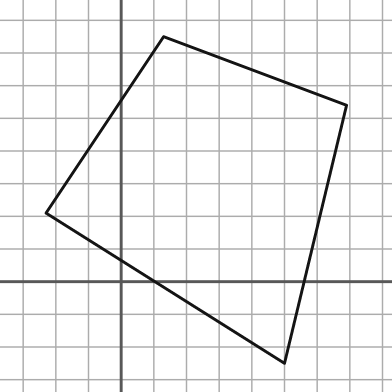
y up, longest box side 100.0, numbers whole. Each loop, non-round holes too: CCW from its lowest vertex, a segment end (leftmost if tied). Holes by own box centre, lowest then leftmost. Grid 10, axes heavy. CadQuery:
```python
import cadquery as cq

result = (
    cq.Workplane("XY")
    .moveTo(50.0, -25.0)
    .lineTo(69.0, 54.0)
    .lineTo(13.0, 75.0)
    .lineTo(-23.0, 21.0)
    .close()
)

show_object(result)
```